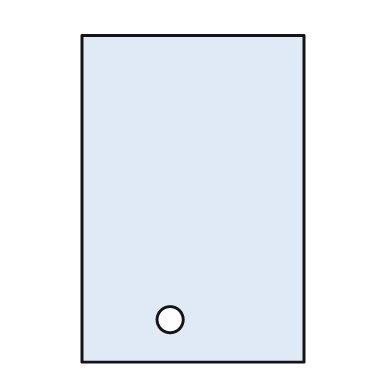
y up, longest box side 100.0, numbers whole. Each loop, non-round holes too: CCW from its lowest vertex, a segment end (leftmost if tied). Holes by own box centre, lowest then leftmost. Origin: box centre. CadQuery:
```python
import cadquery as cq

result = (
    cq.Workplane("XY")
    .moveTo(-34.0, -50.0)
    .lineTo(34.0, -50.0)
    .lineTo(34.0, 50.0)
    .lineTo(-34.0, 50.0)
    .close()
    .moveTo(-7.0, -37.0)
    .circle(4.0)
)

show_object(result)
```